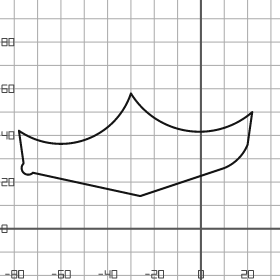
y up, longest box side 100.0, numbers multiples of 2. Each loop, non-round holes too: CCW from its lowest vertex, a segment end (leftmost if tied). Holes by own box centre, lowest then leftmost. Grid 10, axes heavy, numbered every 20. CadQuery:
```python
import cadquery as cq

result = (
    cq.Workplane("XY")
    .moveTo(-26.0, 14.0)
    .lineTo(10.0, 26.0)
    .threePointArc((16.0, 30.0), (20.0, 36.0))
    .lineTo(22.0, 50.0)
    .threePointArc((-6.0, 42.0), (-30.0, 58.0))
    .threePointArc((-50.0, 38.0), (-78.0, 42.0))
    .lineTo(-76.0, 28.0)
    .threePointArc((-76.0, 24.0), (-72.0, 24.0))
    .close()
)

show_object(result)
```